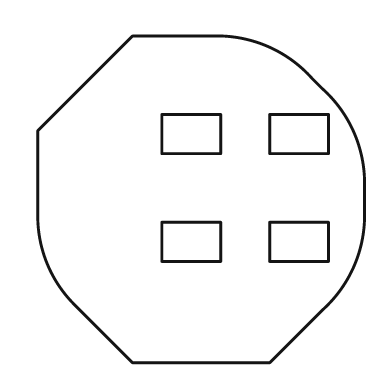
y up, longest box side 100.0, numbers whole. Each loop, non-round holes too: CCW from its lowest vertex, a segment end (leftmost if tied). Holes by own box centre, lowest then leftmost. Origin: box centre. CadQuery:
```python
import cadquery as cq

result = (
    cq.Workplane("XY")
    .moveTo(-21.0, -50.0)
    .lineTo(21.0, -50.0)
    .lineTo(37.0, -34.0)
    .threePointArc((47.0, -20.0), (50.0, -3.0))
    .lineTo(50.0, 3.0)
    .threePointArc((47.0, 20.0), (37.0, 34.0))
    .lineTo(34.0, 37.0)
    .threePointArc((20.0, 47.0), (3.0, 50.0))
    .lineTo(-21.0, 50.0)
    .lineTo(-50.0, 21.0)
    .lineTo(-50.0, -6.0)
    .threePointArc((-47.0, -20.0), (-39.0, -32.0))
    .close()
    .moveTo(-12.0, -19.0)
    .lineTo(6.0, -19.0)
    .lineTo(6.0, -7.0)
    .lineTo(-12.0, -7.0)
    .close()
    .moveTo(21.0, -19.0)
    .lineTo(39.0, -19.0)
    .lineTo(39.0, -7.0)
    .lineTo(21.0, -7.0)
    .close()
    .moveTo(-12.0, 14.0)
    .lineTo(6.0, 14.0)
    .lineTo(6.0, 26.0)
    .lineTo(-12.0, 26.0)
    .close()
    .moveTo(21.0, 14.0)
    .lineTo(39.0, 14.0)
    .lineTo(39.0, 26.0)
    .lineTo(21.0, 26.0)
    .close()
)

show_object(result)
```